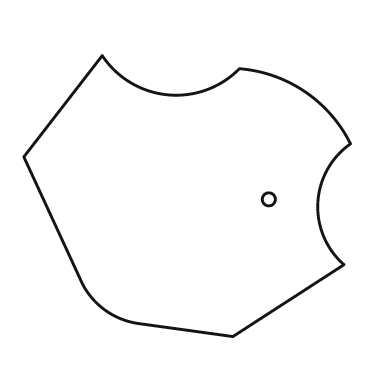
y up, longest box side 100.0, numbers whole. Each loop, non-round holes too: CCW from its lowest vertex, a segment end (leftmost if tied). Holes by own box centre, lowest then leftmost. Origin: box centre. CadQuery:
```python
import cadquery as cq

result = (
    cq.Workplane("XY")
    .moveTo(14.0, -43.0)
    .lineTo(48.0, -21.0)
    .threePointArc((40.0, -2.0), (50.0, 16.0))
    .threePointArc((36.0, 32.0), (16.0, 39.0))
    .threePointArc((-6.0, 31.0), (-26.0, 43.0))
    .lineTo(-50.0, 12.0)
    .lineTo(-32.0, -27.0)
    .threePointArc((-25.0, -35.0), (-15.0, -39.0))
    .close()
    .moveTo(25.0, -1.0)
    .circle(2.0)
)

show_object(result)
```